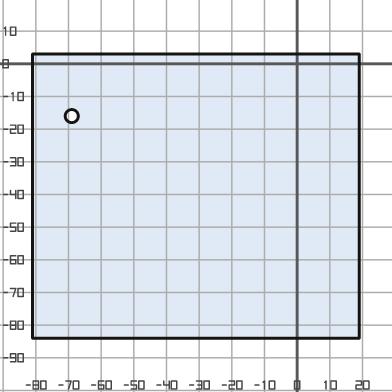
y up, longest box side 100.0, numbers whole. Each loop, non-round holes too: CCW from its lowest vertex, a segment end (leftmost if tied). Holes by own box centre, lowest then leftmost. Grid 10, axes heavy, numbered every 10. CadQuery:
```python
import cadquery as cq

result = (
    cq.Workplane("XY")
    .moveTo(-81.0, -84.0)
    .lineTo(19.0, -84.0)
    .lineTo(19.0, 3.0)
    .lineTo(-81.0, 3.0)
    .close()
    .moveTo(-69.0, -16.0)
    .circle(2.0)
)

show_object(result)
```